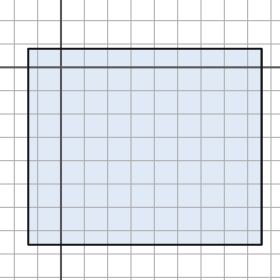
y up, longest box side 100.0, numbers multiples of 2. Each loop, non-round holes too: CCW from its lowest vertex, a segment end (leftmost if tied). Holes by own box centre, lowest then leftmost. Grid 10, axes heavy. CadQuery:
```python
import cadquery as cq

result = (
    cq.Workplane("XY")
    .moveTo(-14.0, -76.0)
    .lineTo(86.0, -76.0)
    .lineTo(86.0, 8.0)
    .lineTo(-14.0, 8.0)
    .close()
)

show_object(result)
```